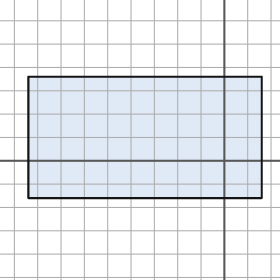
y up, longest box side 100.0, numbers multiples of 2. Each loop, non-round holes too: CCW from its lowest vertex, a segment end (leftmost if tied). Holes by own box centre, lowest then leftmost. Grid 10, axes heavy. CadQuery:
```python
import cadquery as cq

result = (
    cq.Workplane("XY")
    .moveTo(-84.0, -16.0)
    .lineTo(16.0, -16.0)
    .lineTo(16.0, 36.0)
    .lineTo(-84.0, 36.0)
    .close()
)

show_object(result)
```